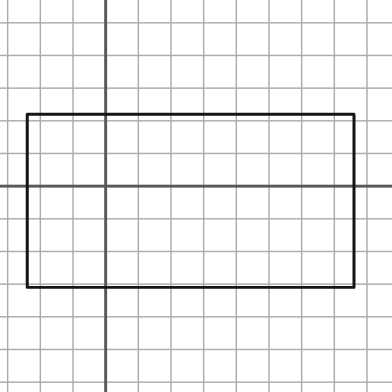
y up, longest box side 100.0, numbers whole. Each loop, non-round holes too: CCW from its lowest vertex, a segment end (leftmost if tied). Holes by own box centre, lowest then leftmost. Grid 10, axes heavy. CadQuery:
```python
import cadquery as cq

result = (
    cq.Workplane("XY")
    .moveTo(-24.0, -31.0)
    .lineTo(76.0, -31.0)
    .lineTo(76.0, 22.0)
    .lineTo(-24.0, 22.0)
    .close()
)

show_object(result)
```